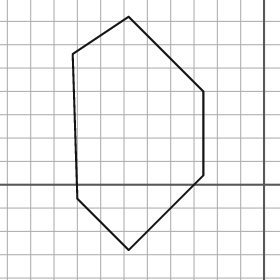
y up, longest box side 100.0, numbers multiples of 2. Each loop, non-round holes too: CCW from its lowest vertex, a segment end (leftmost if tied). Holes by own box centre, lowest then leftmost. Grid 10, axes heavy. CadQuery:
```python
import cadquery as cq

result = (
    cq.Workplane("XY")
    .moveTo(-58.0, -28.0)
    .lineTo(-26.0, 4.0)
    .lineTo(-26.0, 40.0)
    .lineTo(-58.0, 72.0)
    .lineTo(-82.0, 56.0)
    .lineTo(-80.0, -6.0)
    .close()
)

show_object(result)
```